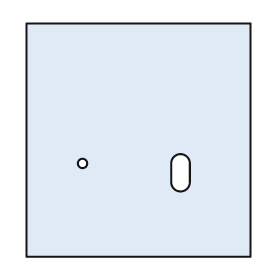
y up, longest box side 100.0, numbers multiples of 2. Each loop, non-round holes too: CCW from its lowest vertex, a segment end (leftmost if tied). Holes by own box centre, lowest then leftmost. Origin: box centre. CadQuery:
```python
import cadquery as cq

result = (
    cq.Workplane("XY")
    .moveTo(-48.0, -50.0)
    .lineTo(48.0, -50.0)
    .lineTo(48.0, 50.0)
    .lineTo(-48.0, 50.0)
    .close()
    .moveTo(14.0, -18.0)
    .threePointArc((18.0, -22.0), (22.0, -18.0))
    .lineTo(22.0, -10.0)
    .threePointArc((18.0, -6.0), (14.0, -10.0))
    .close()
    .moveTo(-24.0, -10.0)
    .circle(2.0)
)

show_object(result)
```